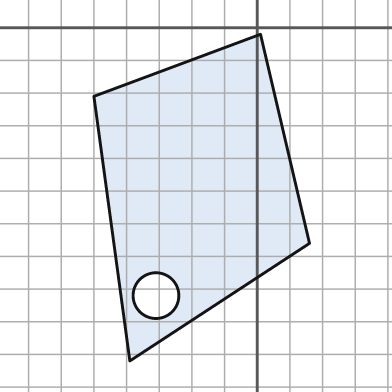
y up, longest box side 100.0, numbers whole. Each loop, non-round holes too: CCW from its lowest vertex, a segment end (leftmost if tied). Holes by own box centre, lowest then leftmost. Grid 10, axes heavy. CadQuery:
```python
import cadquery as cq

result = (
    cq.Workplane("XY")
    .moveTo(-39.0, -102.0)
    .lineTo(16.0, -66.0)
    .lineTo(1.0, -2.0)
    .lineTo(-50.0, -21.0)
    .close()
    .moveTo(-31.0, -82.0)
    .circle(7.0)
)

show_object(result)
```